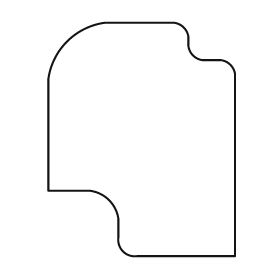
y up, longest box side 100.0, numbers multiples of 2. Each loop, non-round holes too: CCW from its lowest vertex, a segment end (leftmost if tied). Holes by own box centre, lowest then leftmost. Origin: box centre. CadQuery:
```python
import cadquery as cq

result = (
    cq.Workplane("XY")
    .moveTo(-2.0, -50.0)
    .lineTo(40.0, -50.0)
    .lineTo(40.0, 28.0)
    .threePointArc((38.0, 32.0), (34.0, 34.0))
    .lineTo(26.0, 34.0)
    .threePointArc((22.0, 36.0), (20.0, 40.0))
    .lineTo(20.0, 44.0)
    .threePointArc((18.0, 48.0), (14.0, 50.0))
    .lineTo(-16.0, 50.0)
    .threePointArc((-32.0, 42.0), (-40.0, 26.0))
    .lineTo(-40.0, -22.0)
    .lineTo(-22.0, -22.0)
    .threePointArc((-14.0, -26.0), (-10.0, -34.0))
    .lineTo(-10.0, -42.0)
    .threePointArc((-8.0, -48.0), (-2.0, -50.0))
    .close()
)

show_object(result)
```